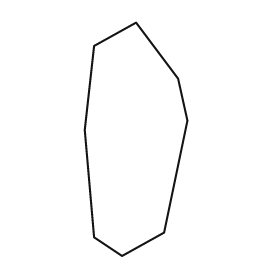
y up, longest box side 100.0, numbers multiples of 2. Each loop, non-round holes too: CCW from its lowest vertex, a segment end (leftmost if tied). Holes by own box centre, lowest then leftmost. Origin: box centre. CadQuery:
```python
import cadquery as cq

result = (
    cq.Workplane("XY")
    .moveTo(-6.0, -50.0)
    .lineTo(12.0, -40.0)
    .lineTo(22.0, 8.0)
    .lineTo(18.0, 26.0)
    .lineTo(0.0, 50.0)
    .lineTo(-18.0, 40.0)
    .lineTo(-22.0, 4.0)
    .lineTo(-18.0, -42.0)
    .close()
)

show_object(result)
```